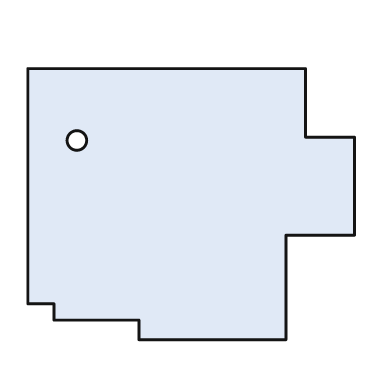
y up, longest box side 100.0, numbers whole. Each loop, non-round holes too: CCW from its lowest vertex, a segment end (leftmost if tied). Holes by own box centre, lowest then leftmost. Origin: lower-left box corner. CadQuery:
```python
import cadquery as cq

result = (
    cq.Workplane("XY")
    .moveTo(34.0, 0.0)
    .lineTo(79.0, 0.0)
    .lineTo(79.0, 32.0)
    .lineTo(100.0, 32.0)
    .lineTo(100.0, 62.0)
    .lineTo(85.0, 62.0)
    .lineTo(85.0, 83.0)
    .lineTo(0.0, 83.0)
    .lineTo(0.0, 11.0)
    .lineTo(8.0, 11.0)
    .lineTo(8.0, 6.0)
    .lineTo(34.0, 6.0)
    .close()
    .moveTo(15.0, 61.0)
    .circle(3.0)
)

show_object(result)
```